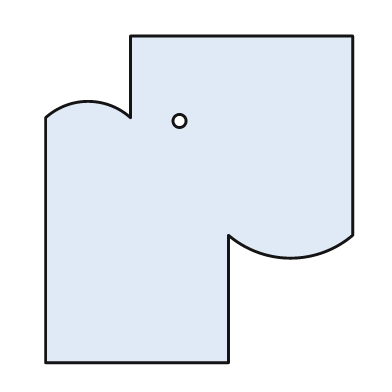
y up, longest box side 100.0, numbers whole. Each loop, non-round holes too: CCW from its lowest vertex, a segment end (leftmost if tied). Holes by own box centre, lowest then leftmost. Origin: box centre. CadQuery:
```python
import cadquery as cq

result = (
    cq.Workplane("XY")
    .moveTo(-47.0, -50.0)
    .lineTo(9.0, -50.0)
    .lineTo(9.0, -11.0)
    .threePointArc((28.0, -18.0), (47.0, -11.0))
    .lineTo(47.0, 50.0)
    .lineTo(-21.0, 50.0)
    .lineTo(-21.0, 25.0)
    .threePointArc((-34.0, 30.0), (-47.0, 25.0))
    .close()
    .moveTo(-6.0, 24.0)
    .circle(2.0)
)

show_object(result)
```